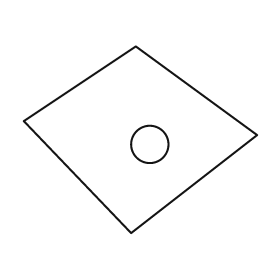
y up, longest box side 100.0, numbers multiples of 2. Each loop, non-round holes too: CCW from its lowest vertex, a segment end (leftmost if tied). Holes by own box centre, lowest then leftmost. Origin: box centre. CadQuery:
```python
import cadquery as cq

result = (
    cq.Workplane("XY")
    .moveTo(-4.0, -40.0)
    .lineTo(50.0, 2.0)
    .lineTo(-2.0, 40.0)
    .lineTo(-50.0, 8.0)
    .close()
    .moveTo(4.0, -2.0)
    .circle(8.0)
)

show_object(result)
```